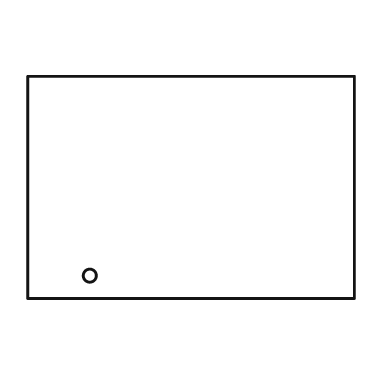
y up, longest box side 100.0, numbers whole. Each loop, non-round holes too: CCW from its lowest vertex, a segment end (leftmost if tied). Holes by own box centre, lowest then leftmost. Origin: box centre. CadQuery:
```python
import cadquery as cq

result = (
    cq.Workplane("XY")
    .moveTo(-50.0, -34.0)
    .lineTo(50.0, -34.0)
    .lineTo(50.0, 34.0)
    .lineTo(-50.0, 34.0)
    .close()
    .moveTo(-31.0, -27.0)
    .circle(2.0)
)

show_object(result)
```